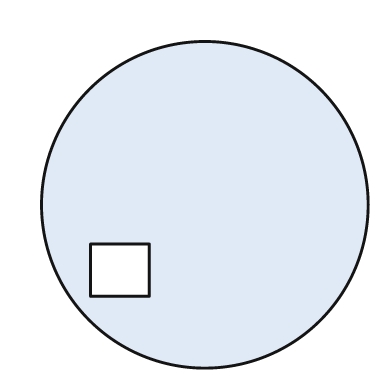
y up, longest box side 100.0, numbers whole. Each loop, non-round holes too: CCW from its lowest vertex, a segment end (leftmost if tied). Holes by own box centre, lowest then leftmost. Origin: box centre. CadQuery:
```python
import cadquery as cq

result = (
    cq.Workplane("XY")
    .moveTo(0.0, 0.0)
    .circle(50.0)
    .moveTo(-35.0, -28.0)
    .lineTo(-17.0, -28.0)
    .lineTo(-17.0, -12.0)
    .lineTo(-35.0, -12.0)
    .close()
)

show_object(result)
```